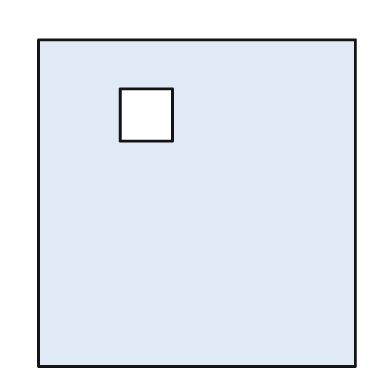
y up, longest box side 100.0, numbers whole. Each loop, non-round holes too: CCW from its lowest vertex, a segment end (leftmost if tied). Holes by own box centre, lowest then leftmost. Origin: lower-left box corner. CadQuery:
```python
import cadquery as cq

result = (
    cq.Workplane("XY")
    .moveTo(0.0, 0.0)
    .lineTo(97.0, 0.0)
    .lineTo(97.0, 100.0)
    .lineTo(0.0, 100.0)
    .close()
    .moveTo(25.0, 69.0)
    .lineTo(41.0, 69.0)
    .lineTo(41.0, 85.0)
    .lineTo(25.0, 85.0)
    .close()
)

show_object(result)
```